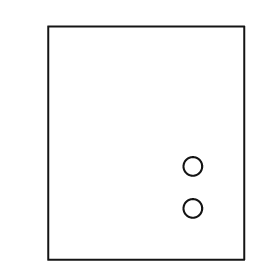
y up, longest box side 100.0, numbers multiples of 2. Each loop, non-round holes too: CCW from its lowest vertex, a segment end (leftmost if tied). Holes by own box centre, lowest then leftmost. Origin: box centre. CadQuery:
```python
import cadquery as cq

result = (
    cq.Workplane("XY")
    .moveTo(-42.0, -50.0)
    .lineTo(42.0, -50.0)
    .lineTo(42.0, 50.0)
    .lineTo(-42.0, 50.0)
    .close()
    .moveTo(20.0, -28.0)
    .circle(4.0)
    .moveTo(20.0, -10.0)
    .circle(4.0)
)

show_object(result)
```